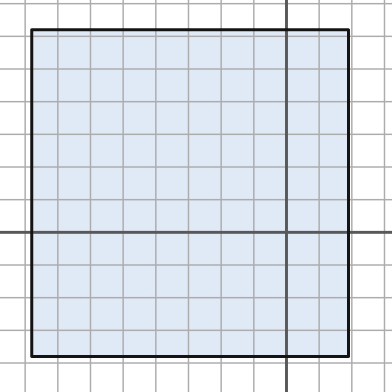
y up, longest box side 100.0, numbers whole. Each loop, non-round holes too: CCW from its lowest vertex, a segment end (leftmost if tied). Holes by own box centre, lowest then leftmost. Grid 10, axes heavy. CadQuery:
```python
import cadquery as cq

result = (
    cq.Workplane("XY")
    .moveTo(-78.0, -38.0)
    .lineTo(19.0, -38.0)
    .lineTo(19.0, 62.0)
    .lineTo(-78.0, 62.0)
    .close()
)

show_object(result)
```